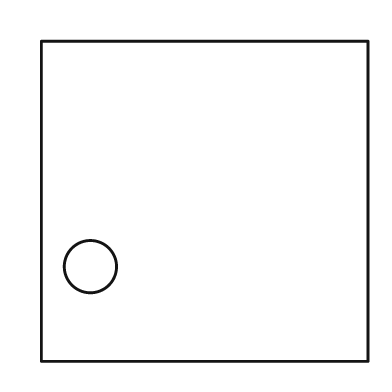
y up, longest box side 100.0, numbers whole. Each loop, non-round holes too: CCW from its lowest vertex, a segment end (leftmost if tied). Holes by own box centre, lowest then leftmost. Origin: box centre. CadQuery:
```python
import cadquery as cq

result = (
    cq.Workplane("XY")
    .moveTo(-50.0, -49.0)
    .lineTo(50.0, -49.0)
    .lineTo(50.0, 49.0)
    .lineTo(-50.0, 49.0)
    .close()
    .moveTo(-35.0, -20.0)
    .circle(8.0)
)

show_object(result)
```